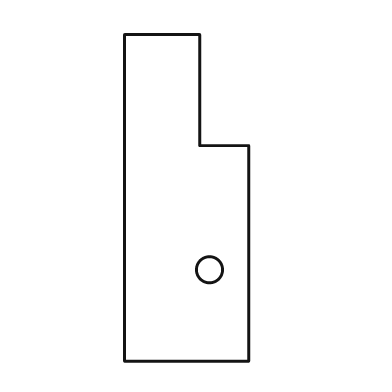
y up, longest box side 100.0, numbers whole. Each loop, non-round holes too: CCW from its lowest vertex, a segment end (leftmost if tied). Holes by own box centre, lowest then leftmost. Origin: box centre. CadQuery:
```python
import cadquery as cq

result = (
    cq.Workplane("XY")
    .moveTo(-19.0, -50.0)
    .lineTo(19.0, -50.0)
    .lineTo(19.0, 16.0)
    .lineTo(4.0, 16.0)
    .lineTo(4.0, 50.0)
    .lineTo(-19.0, 50.0)
    .close()
    .moveTo(7.0, -22.0)
    .circle(4.0)
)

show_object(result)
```